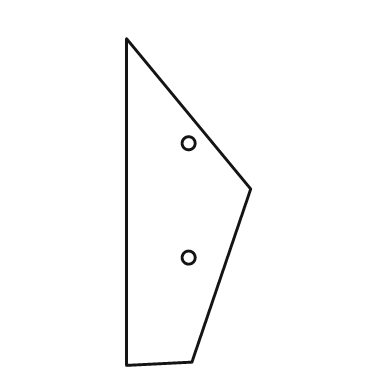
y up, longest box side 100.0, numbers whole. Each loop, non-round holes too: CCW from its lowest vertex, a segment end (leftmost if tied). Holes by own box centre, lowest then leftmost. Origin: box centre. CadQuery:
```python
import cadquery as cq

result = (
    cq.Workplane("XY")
    .moveTo(-19.0, -50.0)
    .lineTo(1.0, -49.0)
    .lineTo(19.0, 4.0)
    .lineTo(-19.0, 50.0)
    .close()
    .moveTo(0.0, -17.0)
    .circle(2.0)
    .moveTo(0.0, 18.0)
    .circle(2.0)
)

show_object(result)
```